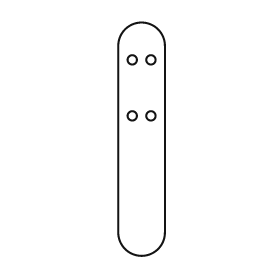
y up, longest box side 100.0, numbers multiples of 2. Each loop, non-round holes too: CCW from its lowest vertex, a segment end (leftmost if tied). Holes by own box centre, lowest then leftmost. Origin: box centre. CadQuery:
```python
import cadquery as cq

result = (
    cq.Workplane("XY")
    .moveTo(-10.0, -40.0)
    .threePointArc((0.0, -50.0), (10.0, -40.0))
    .lineTo(10.0, 40.0)
    .threePointArc((0.0, 50.0), (-10.0, 40.0))
    .close()
    .moveTo(-4.0, 10.0)
    .circle(2.0)
    .moveTo(4.0, 10.0)
    .circle(2.0)
    .moveTo(-4.0, 34.0)
    .circle(2.0)
    .moveTo(4.0, 34.0)
    .circle(2.0)
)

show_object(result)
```